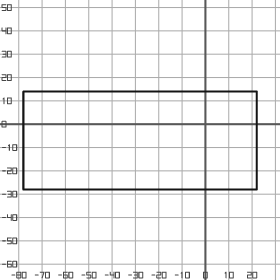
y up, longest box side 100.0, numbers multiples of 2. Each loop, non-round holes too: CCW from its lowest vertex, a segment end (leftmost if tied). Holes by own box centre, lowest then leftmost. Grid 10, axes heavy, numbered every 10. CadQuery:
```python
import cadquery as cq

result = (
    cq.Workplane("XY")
    .moveTo(-78.0, -28.0)
    .lineTo(22.0, -28.0)
    .lineTo(22.0, 14.0)
    .lineTo(-78.0, 14.0)
    .close()
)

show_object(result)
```